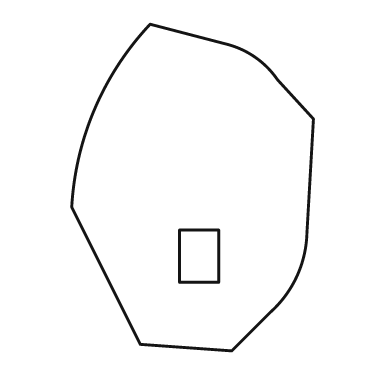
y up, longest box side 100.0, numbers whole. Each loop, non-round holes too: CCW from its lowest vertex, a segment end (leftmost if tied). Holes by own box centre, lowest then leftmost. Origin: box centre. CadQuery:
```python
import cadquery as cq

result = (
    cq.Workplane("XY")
    .moveTo(12.0, -50.0)
    .lineTo(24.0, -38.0)
    .threePointArc((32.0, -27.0), (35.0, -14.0))
    .lineTo(37.0, 21.0)
    .lineTo(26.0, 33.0)
    .threePointArc((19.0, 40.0), (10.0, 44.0))
    .lineTo(-13.0, 50.0)
    .threePointArc((-30.0, 24.0), (-37.0, -6.0))
    .lineTo(-16.0, -48.0)
    .close()
    .moveTo(-4.0, -29.0)
    .lineTo(8.0, -29.0)
    .lineTo(8.0, -13.0)
    .lineTo(-4.0, -13.0)
    .close()
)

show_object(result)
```